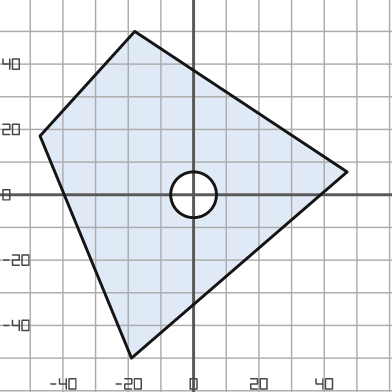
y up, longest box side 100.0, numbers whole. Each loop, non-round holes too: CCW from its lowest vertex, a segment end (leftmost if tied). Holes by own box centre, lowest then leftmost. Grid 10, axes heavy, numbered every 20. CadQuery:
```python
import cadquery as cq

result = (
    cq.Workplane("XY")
    .moveTo(-19.0, -50.0)
    .lineTo(47.0, 7.0)
    .lineTo(-18.0, 50.0)
    .lineTo(-47.0, 18.0)
    .close()
    .moveTo(0.0, 0.0)
    .circle(7.0)
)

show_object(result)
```